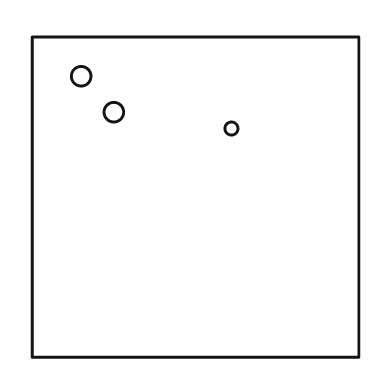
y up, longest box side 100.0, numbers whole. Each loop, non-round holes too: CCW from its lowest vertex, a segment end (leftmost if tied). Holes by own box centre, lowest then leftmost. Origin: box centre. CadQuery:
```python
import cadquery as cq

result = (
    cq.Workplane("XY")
    .moveTo(-50.0, -49.0)
    .lineTo(50.0, -49.0)
    .lineTo(50.0, 49.0)
    .lineTo(-50.0, 49.0)
    .close()
    .moveTo(11.0, 21.0)
    .circle(2.0)
    .moveTo(-25.0, 26.0)
    .circle(3.0)
    .moveTo(-35.0, 37.0)
    .circle(3.0)
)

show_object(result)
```